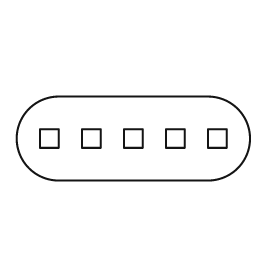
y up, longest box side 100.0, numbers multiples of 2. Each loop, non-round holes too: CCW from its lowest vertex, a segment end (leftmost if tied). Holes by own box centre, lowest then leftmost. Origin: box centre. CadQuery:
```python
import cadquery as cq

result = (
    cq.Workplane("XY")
    .moveTo(-32.0, -18.0)
    .lineTo(32.0, -18.0)
    .threePointArc((50.0, 0.0), (32.0, 18.0))
    .lineTo(-32.0, 18.0)
    .threePointArc((-50.0, 0.0), (-32.0, -18.0))
    .close()
    .moveTo(-40.0, -4.0)
    .lineTo(-32.0, -4.0)
    .lineTo(-32.0, 4.0)
    .lineTo(-40.0, 4.0)
    .close()
    .moveTo(-22.0, -4.0)
    .lineTo(-14.0, -4.0)
    .lineTo(-14.0, 4.0)
    .lineTo(-22.0, 4.0)
    .close()
    .moveTo(-4.0, -4.0)
    .lineTo(4.0, -4.0)
    .lineTo(4.0, 4.0)
    .lineTo(-4.0, 4.0)
    .close()
    .moveTo(14.0, -4.0)
    .lineTo(22.0, -4.0)
    .lineTo(22.0, 4.0)
    .lineTo(14.0, 4.0)
    .close()
    .moveTo(32.0, -4.0)
    .lineTo(40.0, -4.0)
    .lineTo(40.0, 4.0)
    .lineTo(32.0, 4.0)
    .close()
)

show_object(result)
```